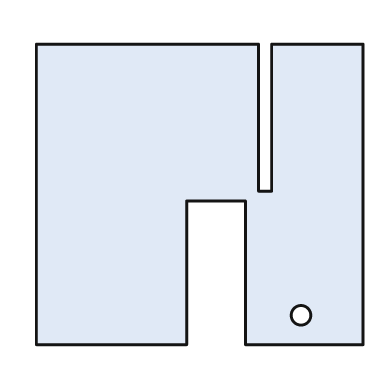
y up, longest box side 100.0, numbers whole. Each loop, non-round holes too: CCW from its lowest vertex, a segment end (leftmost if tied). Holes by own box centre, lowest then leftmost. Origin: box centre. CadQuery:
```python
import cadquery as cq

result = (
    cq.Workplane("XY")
    .moveTo(-50.0, -46.0)
    .lineTo(-4.0, -46.0)
    .lineTo(-4.0, -2.0)
    .lineTo(14.0, -2.0)
    .lineTo(14.0, -46.0)
    .lineTo(50.0, -46.0)
    .lineTo(50.0, 46.0)
    .lineTo(22.0, 46.0)
    .lineTo(22.0, 1.0)
    .lineTo(18.0, 1.0)
    .lineTo(18.0, 46.0)
    .lineTo(-50.0, 46.0)
    .close()
    .moveTo(31.0, -37.0)
    .circle(3.0)
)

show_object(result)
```